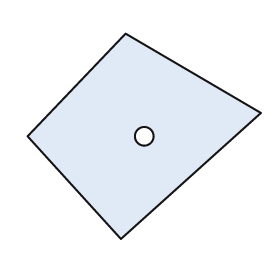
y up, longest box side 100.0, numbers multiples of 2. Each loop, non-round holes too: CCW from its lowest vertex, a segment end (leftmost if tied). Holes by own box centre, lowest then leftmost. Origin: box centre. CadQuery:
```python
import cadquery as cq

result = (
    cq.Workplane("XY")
    .moveTo(-10.0, -44.0)
    .lineTo(50.0, 10.0)
    .lineTo(-8.0, 44.0)
    .lineTo(-50.0, 0.0)
    .close()
    .moveTo(0.0, 0.0)
    .circle(4.0)
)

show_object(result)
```